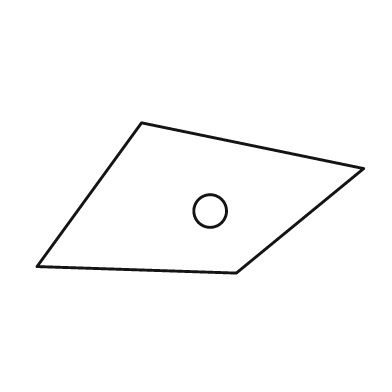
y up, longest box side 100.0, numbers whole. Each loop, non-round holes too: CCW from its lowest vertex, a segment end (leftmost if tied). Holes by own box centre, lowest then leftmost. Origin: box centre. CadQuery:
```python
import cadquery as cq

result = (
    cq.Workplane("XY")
    .moveTo(11.0, -23.0)
    .lineTo(50.0, 9.0)
    .lineTo(-18.0, 23.0)
    .lineTo(-50.0, -21.0)
    .close()
    .moveTo(3.0, -4.0)
    .circle(5.0)
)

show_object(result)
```